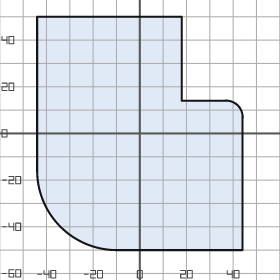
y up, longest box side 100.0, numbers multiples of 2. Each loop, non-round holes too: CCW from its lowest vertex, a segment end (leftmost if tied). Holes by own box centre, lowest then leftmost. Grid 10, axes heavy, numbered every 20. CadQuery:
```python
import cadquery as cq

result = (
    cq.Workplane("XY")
    .moveTo(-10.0, -50.0)
    .lineTo(44.0, -50.0)
    .lineTo(44.0, 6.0)
    .threePointArc((42.0, 12.0), (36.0, 14.0))
    .lineTo(18.0, 14.0)
    .lineTo(18.0, 50.0)
    .lineTo(-44.0, 50.0)
    .lineTo(-44.0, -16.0)
    .threePointArc((-34.0, -40.0), (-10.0, -50.0))
    .close()
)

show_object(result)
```